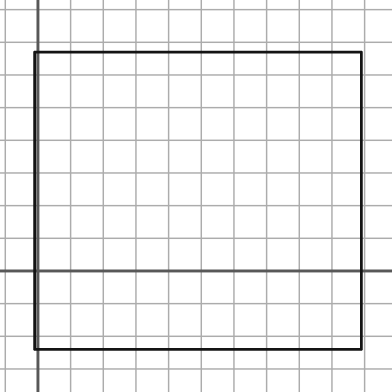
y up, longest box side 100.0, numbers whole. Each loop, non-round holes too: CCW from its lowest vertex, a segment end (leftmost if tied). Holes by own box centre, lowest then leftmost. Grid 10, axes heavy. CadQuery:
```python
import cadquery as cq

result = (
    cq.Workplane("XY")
    .moveTo(-1.0, -24.0)
    .lineTo(99.0, -24.0)
    .lineTo(99.0, 67.0)
    .lineTo(-1.0, 67.0)
    .close()
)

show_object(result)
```